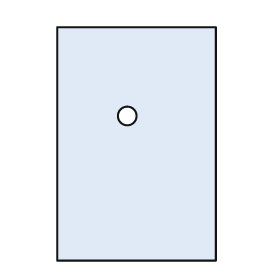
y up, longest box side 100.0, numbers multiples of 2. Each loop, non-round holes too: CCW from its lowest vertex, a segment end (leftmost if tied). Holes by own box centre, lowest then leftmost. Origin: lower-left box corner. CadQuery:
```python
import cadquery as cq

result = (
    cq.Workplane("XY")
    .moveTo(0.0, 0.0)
    .lineTo(68.0, 0.0)
    .lineTo(68.0, 100.0)
    .lineTo(0.0, 100.0)
    .close()
    .moveTo(30.0, 62.0)
    .circle(4.0)
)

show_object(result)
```